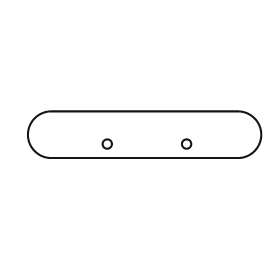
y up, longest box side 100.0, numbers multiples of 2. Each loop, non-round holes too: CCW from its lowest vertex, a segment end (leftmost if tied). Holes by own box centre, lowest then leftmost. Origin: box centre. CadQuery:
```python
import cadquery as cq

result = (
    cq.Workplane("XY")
    .moveTo(-40.0, -10.0)
    .lineTo(40.0, -10.0)
    .threePointArc((50.0, 0.0), (40.0, 10.0))
    .lineTo(-40.0, 10.0)
    .threePointArc((-50.0, 0.0), (-40.0, -10.0))
    .close()
    .moveTo(-16.0, -4.0)
    .circle(2.0)
    .moveTo(18.0, -4.0)
    .circle(2.0)
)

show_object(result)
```